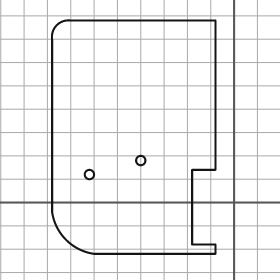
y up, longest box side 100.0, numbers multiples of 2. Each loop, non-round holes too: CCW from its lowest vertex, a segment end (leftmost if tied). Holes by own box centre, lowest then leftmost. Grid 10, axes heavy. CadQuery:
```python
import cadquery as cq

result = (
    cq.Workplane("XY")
    .moveTo(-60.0, -22.0)
    .lineTo(-8.0, -22.0)
    .lineTo(-8.0, -18.0)
    .lineTo(-18.0, -18.0)
    .lineTo(-18.0, 14.0)
    .lineTo(-8.0, 14.0)
    .lineTo(-8.0, 78.0)
    .lineTo(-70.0, 78.0)
    .threePointArc((-76.0, 76.0), (-78.0, 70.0))
    .lineTo(-78.0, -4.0)
    .threePointArc((-72.0, -16.0), (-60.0, -22.0))
    .close()
    .moveTo(-62.0, 12.0)
    .circle(2.0)
    .moveTo(-40.0, 18.0)
    .circle(2.0)
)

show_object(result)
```